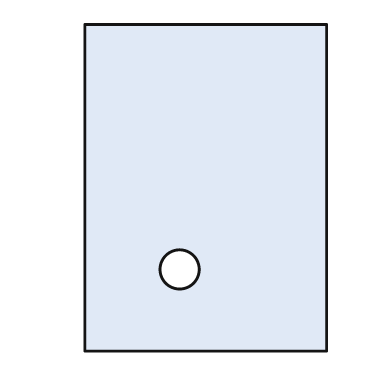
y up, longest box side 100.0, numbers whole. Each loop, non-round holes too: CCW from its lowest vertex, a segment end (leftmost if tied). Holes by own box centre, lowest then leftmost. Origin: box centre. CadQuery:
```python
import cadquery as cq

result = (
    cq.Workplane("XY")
    .moveTo(-37.0, -50.0)
    .lineTo(37.0, -50.0)
    .lineTo(37.0, 50.0)
    .lineTo(-37.0, 50.0)
    .close()
    .moveTo(-8.0, -25.0)
    .circle(6.0)
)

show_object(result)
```